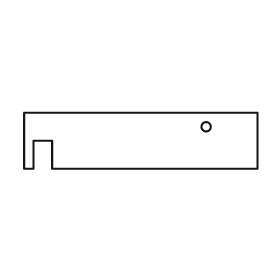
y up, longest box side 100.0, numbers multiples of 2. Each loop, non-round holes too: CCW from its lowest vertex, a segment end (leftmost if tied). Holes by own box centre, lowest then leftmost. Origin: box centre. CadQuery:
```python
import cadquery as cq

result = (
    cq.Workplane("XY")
    .moveTo(-50.0, -12.0)
    .lineTo(-46.0, -12.0)
    .lineTo(-46.0, 0.0)
    .lineTo(-38.0, 0.0)
    .lineTo(-38.0, -12.0)
    .lineTo(50.0, -12.0)
    .lineTo(50.0, 12.0)
    .lineTo(-50.0, 12.0)
    .close()
    .moveTo(28.0, 6.0)
    .circle(2.0)
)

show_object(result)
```